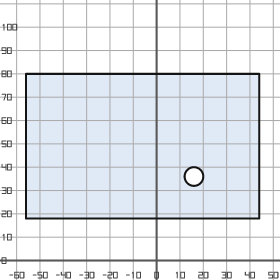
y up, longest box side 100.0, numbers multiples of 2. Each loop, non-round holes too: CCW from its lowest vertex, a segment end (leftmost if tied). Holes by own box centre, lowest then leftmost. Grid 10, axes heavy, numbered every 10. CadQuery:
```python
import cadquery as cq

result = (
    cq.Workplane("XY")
    .moveTo(-56.0, 18.0)
    .lineTo(44.0, 18.0)
    .lineTo(44.0, 80.0)
    .lineTo(-56.0, 80.0)
    .close()
    .moveTo(16.0, 36.0)
    .circle(4.0)
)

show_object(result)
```